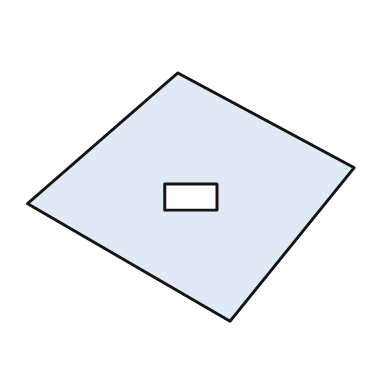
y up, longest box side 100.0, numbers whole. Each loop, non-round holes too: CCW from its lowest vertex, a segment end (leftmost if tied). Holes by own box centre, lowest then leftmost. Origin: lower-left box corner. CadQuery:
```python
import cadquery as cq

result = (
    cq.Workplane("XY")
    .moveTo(62.0, 0.0)
    .lineTo(100.0, 47.0)
    .lineTo(46.0, 76.0)
    .lineTo(0.0, 36.0)
    .close()
    .moveTo(42.0, 34.0)
    .lineTo(58.0, 34.0)
    .lineTo(58.0, 42.0)
    .lineTo(42.0, 42.0)
    .close()
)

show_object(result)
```